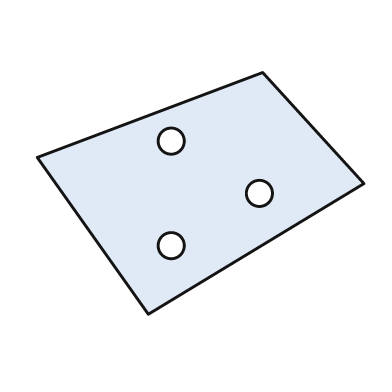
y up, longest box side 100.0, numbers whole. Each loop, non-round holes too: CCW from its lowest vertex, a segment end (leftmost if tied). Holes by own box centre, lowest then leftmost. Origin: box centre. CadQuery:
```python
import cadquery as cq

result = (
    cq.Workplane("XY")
    .moveTo(-16.0, -37.0)
    .lineTo(50.0, 3.0)
    .lineTo(19.0, 37.0)
    .lineTo(-50.0, 11.0)
    .close()
    .moveTo(-9.0, -16.0)
    .circle(4.0)
    .moveTo(18.0, 0.0)
    .circle(4.0)
    .moveTo(-9.0, 16.0)
    .circle(4.0)
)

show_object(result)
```